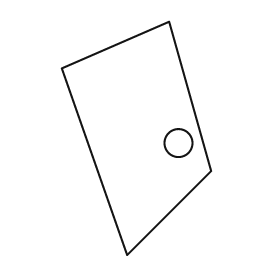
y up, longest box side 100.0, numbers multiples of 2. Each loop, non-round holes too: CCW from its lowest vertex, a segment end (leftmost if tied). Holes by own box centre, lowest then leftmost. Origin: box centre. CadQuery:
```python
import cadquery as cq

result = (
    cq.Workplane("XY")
    .moveTo(-4.0, -50.0)
    .lineTo(32.0, -14.0)
    .lineTo(14.0, 50.0)
    .lineTo(-32.0, 30.0)
    .close()
    .moveTo(18.0, -2.0)
    .circle(6.0)
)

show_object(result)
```